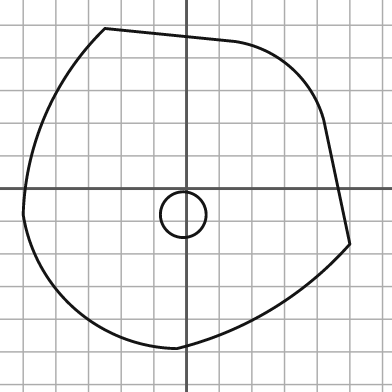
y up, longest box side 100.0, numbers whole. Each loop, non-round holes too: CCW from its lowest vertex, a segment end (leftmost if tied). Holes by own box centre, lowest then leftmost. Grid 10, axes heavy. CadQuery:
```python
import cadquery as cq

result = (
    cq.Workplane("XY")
    .moveTo(-3.0, -49.0)
    .threePointArc((26.0, -37.0), (50.0, -17.0))
    .lineTo(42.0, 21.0)
    .threePointArc((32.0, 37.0), (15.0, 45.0))
    .lineTo(-25.0, 49.0)
    .threePointArc((-43.0, 23.0), (-50.0, -8.0))
    .threePointArc((-34.0, -37.0), (-3.0, -49.0))
    .close()
    .moveTo(-1.0, -8.0)
    .circle(7.0)
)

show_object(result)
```